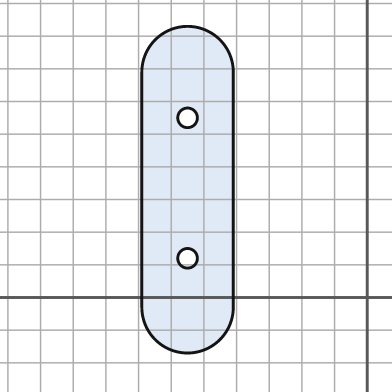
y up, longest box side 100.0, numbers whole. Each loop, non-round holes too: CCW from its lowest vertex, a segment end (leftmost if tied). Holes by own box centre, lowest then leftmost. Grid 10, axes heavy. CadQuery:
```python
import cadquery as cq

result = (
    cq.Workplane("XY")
    .moveTo(-69.0, -3.0)
    .threePointArc((-55.0, -17.0), (-41.0, -3.0))
    .lineTo(-41.0, 69.0)
    .threePointArc((-55.0, 83.0), (-69.0, 69.0))
    .close()
    .moveTo(-55.0, 12.0)
    .circle(3.0)
    .moveTo(-55.0, 55.0)
    .circle(3.0)
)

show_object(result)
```